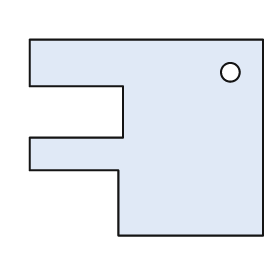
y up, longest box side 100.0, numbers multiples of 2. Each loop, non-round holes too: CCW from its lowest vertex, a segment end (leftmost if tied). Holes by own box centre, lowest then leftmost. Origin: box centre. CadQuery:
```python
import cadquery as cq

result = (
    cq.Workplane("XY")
    .moveTo(-12.0, -42.0)
    .lineTo(50.0, -42.0)
    .lineTo(50.0, 42.0)
    .lineTo(-50.0, 42.0)
    .lineTo(-50.0, 22.0)
    .lineTo(-10.0, 22.0)
    .lineTo(-10.0, 0.0)
    .lineTo(-50.0, 0.0)
    .lineTo(-50.0, -14.0)
    .lineTo(-12.0, -14.0)
    .close()
    .moveTo(36.0, 28.0)
    .circle(4.0)
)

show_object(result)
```